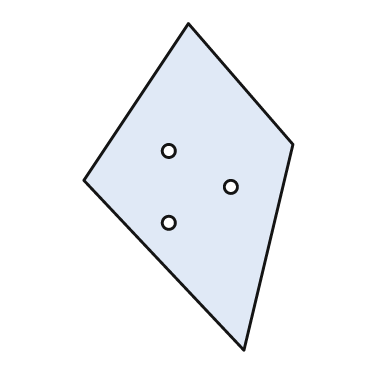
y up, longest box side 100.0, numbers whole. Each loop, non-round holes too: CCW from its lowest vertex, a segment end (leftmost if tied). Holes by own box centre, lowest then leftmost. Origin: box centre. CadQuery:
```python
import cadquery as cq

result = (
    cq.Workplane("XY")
    .moveTo(17.0, -50.0)
    .lineTo(32.0, 13.0)
    .lineTo(0.0, 50.0)
    .lineTo(-32.0, 2.0)
    .close()
    .moveTo(-6.0, -11.0)
    .circle(2.0)
    .moveTo(13.0, 0.0)
    .circle(2.0)
    .moveTo(-6.0, 11.0)
    .circle(2.0)
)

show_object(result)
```